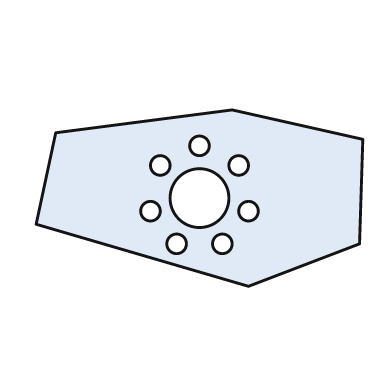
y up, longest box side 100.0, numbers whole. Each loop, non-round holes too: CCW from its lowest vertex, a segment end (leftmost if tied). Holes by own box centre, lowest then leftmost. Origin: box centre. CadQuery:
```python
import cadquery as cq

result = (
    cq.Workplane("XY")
    .moveTo(15.0, -27.0)
    .lineTo(49.0, -14.0)
    .lineTo(50.0, 18.0)
    .lineTo(10.0, 27.0)
    .lineTo(-44.0, 20.0)
    .lineTo(-50.0, -8.0)
    .close()
    .moveTo(-7.0, -14.0)
    .circle(3.0)
    .moveTo(7.0, -14.0)
    .circle(3.0)
    .moveTo(-15.0, -4.0)
    .circle(3.0)
    .moveTo(15.0, -4.0)
    .circle(3.0)
    .moveTo(0.0, 0.0)
    .circle(9.0)
    .moveTo(-12.0, 10.0)
    .circle(3.0)
    .moveTo(12.0, 10.0)
    .circle(3.0)
    .moveTo(0.0, 16.0)
    .circle(3.0)
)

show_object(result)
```